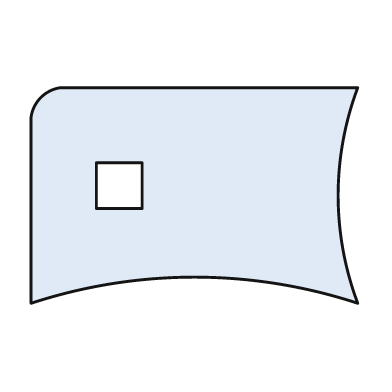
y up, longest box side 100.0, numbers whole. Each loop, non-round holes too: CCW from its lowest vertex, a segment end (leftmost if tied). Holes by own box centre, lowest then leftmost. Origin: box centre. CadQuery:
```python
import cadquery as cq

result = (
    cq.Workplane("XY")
    .moveTo(-50.0, -33.0)
    .threePointArc((0.0, -25.0), (50.0, -33.0))
    .threePointArc((44.0, 0.0), (50.0, 33.0))
    .lineTo(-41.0, 33.0)
    .threePointArc((-47.0, 30.0), (-50.0, 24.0))
    .close()
    .moveTo(-30.0, -4.0)
    .lineTo(-16.0, -4.0)
    .lineTo(-16.0, 10.0)
    .lineTo(-30.0, 10.0)
    .close()
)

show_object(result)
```